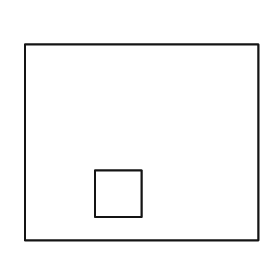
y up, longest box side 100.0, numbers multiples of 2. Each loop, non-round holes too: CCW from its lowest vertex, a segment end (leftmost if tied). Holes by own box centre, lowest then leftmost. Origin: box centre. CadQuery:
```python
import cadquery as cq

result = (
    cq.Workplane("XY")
    .moveTo(-50.0, -42.0)
    .lineTo(50.0, -42.0)
    .lineTo(50.0, 42.0)
    .lineTo(-50.0, 42.0)
    .close()
    .moveTo(-20.0, -32.0)
    .lineTo(0.0, -32.0)
    .lineTo(0.0, -12.0)
    .lineTo(-20.0, -12.0)
    .close()
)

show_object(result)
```